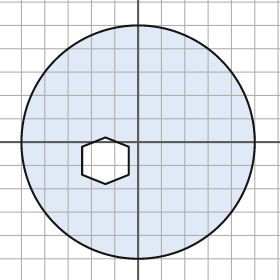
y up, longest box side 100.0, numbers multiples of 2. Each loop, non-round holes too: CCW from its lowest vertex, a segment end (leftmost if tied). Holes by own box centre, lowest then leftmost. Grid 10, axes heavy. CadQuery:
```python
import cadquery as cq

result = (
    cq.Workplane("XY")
    .moveTo(0.0, 0.0)
    .circle(50.0)
    .moveTo(-14.0, -18.0)
    .lineTo(-4.0, -14.0)
    .lineTo(-4.0, -2.0)
    .lineTo(-14.0, 2.0)
    .lineTo(-24.0, -2.0)
    .lineTo(-24.0, -14.0)
    .close()
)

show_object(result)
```